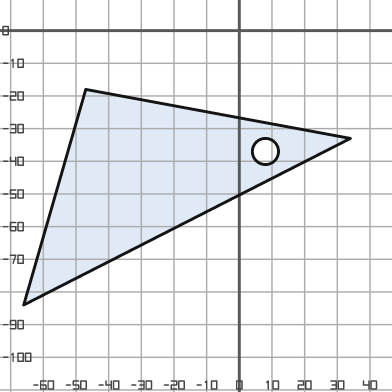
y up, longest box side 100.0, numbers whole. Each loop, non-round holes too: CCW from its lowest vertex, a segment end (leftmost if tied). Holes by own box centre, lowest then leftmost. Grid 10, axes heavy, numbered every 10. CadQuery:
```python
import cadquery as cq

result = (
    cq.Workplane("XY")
    .moveTo(-66.0, -84.0)
    .lineTo(34.0, -33.0)
    .lineTo(-47.0, -18.0)
    .close()
    .moveTo(8.0, -37.0)
    .circle(4.0)
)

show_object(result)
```